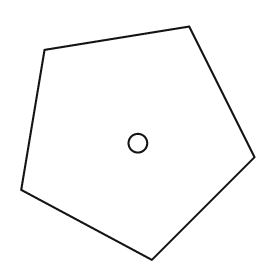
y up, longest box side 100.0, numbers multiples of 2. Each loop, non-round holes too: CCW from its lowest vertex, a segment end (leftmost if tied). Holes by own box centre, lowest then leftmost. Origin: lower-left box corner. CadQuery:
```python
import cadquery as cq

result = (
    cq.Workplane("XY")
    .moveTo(56.0, 0.0)
    .lineTo(100.0, 44.0)
    .lineTo(72.0, 100.0)
    .lineTo(10.0, 90.0)
    .lineTo(0.0, 30.0)
    .close()
    .moveTo(50.0, 50.0)
    .circle(4.0)
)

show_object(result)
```